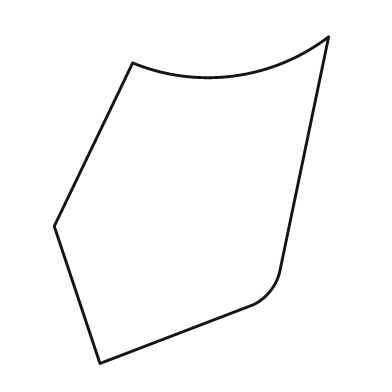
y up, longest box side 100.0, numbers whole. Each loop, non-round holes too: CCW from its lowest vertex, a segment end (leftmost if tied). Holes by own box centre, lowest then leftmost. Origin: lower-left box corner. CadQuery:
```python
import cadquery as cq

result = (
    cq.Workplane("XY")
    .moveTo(14.0, 0.0)
    .lineTo(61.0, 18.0)
    .threePointArc((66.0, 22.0), (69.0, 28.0))
    .lineTo(84.0, 100.0)
    .threePointArc((55.0, 88.0), (24.0, 92.0))
    .lineTo(0.0, 42.0)
    .close()
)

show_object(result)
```